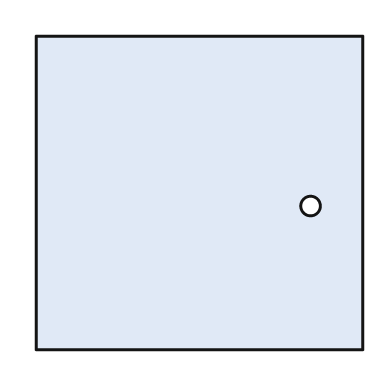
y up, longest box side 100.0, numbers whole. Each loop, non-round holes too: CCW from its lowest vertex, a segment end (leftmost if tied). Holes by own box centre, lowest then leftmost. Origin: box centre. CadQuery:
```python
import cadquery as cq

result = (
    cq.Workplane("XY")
    .moveTo(-50.0, -48.0)
    .lineTo(50.0, -48.0)
    .lineTo(50.0, 48.0)
    .lineTo(-50.0, 48.0)
    .close()
    .moveTo(34.0, -4.0)
    .circle(3.0)
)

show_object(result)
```